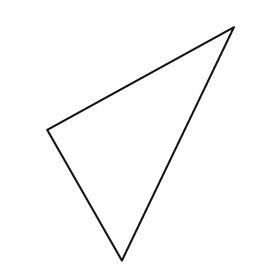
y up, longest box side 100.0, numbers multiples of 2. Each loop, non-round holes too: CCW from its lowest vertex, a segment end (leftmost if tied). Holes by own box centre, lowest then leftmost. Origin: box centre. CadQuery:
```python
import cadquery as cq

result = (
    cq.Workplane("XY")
    .moveTo(-8.0, -50.0)
    .lineTo(40.0, 50.0)
    .lineTo(-40.0, 6.0)
    .close()
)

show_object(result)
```